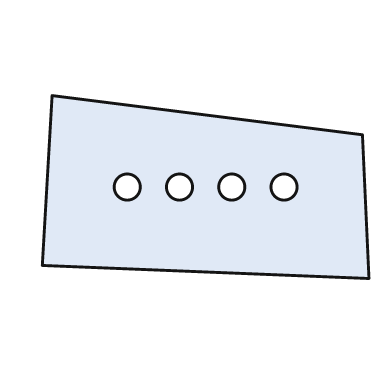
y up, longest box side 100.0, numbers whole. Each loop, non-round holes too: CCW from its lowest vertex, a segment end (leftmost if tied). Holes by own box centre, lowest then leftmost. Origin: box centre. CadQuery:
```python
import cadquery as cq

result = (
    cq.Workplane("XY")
    .moveTo(50.0, -28.0)
    .lineTo(48.0, 16.0)
    .lineTo(-47.0, 28.0)
    .lineTo(-50.0, -24.0)
    .close()
    .moveTo(-24.0, 0.0)
    .circle(4.0)
    .moveTo(-8.0, 0.0)
    .circle(4.0)
    .moveTo(8.0, 0.0)
    .circle(4.0)
    .moveTo(24.0, 0.0)
    .circle(4.0)
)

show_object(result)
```